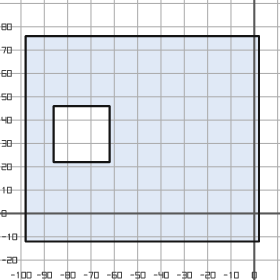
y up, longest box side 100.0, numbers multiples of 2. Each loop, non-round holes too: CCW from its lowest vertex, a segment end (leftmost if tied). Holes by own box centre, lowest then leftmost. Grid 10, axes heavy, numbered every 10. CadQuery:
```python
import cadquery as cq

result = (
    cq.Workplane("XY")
    .moveTo(-98.0, -12.0)
    .lineTo(2.0, -12.0)
    .lineTo(2.0, 76.0)
    .lineTo(-98.0, 76.0)
    .close()
    .moveTo(-86.0, 22.0)
    .lineTo(-62.0, 22.0)
    .lineTo(-62.0, 46.0)
    .lineTo(-86.0, 46.0)
    .close()
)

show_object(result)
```